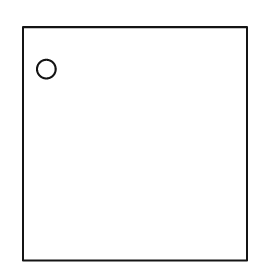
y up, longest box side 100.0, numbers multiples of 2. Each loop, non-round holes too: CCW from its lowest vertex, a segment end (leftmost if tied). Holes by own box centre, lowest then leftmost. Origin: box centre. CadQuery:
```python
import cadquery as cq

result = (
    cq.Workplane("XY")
    .moveTo(-48.0, -50.0)
    .lineTo(48.0, -50.0)
    .lineTo(48.0, 50.0)
    .lineTo(-48.0, 50.0)
    .close()
    .moveTo(-38.0, 32.0)
    .circle(4.0)
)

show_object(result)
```